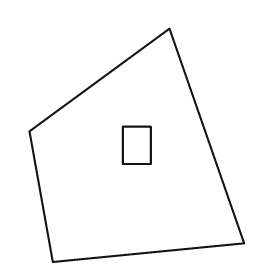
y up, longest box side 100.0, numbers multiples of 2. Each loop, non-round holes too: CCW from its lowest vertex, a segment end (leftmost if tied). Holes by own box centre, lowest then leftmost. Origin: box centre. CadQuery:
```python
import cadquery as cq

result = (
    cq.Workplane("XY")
    .moveTo(-36.0, -50.0)
    .lineTo(46.0, -42.0)
    .lineTo(14.0, 50.0)
    .lineTo(-46.0, 6.0)
    .close()
    .moveTo(-6.0, -8.0)
    .lineTo(6.0, -8.0)
    .lineTo(6.0, 8.0)
    .lineTo(-6.0, 8.0)
    .close()
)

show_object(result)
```